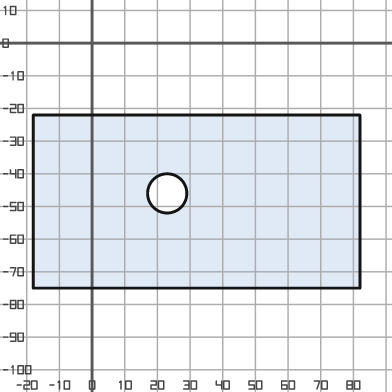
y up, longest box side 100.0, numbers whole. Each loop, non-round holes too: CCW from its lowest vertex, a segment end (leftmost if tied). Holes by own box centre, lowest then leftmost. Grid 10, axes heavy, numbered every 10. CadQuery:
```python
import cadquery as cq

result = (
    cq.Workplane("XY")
    .moveTo(-18.0, -75.0)
    .lineTo(82.0, -75.0)
    .lineTo(82.0, -22.0)
    .lineTo(-18.0, -22.0)
    .close()
    .moveTo(23.0, -46.0)
    .circle(6.0)
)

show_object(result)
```